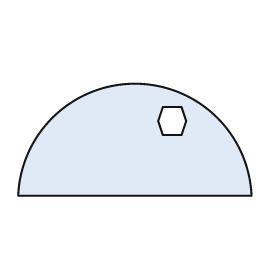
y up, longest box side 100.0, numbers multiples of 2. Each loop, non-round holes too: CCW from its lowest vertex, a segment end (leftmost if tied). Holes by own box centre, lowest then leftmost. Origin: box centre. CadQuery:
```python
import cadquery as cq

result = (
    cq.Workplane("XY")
    .moveTo(-50.0, -24.0)
    .lineTo(50.0, -24.0)
    .threePointArc((0.0, 24.0), (-50.0, -24.0))
    .close()
    .moveTo(12.0, 2.0)
    .lineTo(20.0, 2.0)
    .lineTo(22.0, 8.0)
    .lineTo(20.0, 14.0)
    .lineTo(12.0, 14.0)
    .lineTo(10.0, 8.0)
    .close()
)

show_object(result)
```